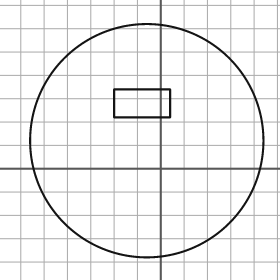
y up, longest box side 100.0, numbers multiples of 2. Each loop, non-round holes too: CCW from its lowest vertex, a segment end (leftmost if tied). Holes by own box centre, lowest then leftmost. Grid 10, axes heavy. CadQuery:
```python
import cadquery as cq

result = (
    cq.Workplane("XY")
    .moveTo(-6.0, 12.0)
    .circle(50.0)
    .moveTo(-20.0, 22.0)
    .lineTo(4.0, 22.0)
    .lineTo(4.0, 34.0)
    .lineTo(-20.0, 34.0)
    .close()
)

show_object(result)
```